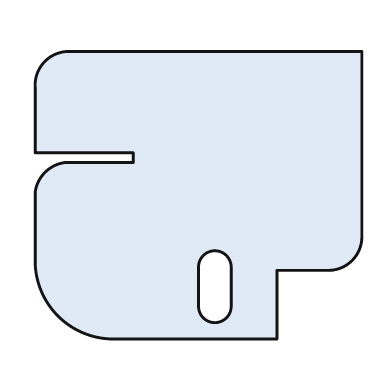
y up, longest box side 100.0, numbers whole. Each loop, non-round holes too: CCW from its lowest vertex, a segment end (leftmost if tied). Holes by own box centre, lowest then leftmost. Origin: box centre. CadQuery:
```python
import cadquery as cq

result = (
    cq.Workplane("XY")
    .moveTo(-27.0, -44.0)
    .lineTo(24.0, -44.0)
    .lineTo(24.0, -23.0)
    .lineTo(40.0, -23.0)
    .threePointArc((47.0, -20.0), (50.0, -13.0))
    .lineTo(50.0, 44.0)
    .lineTo(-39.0, 44.0)
    .threePointArc((-47.0, 41.0), (-50.0, 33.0))
    .lineTo(-50.0, 13.0)
    .lineTo(-20.0, 13.0)
    .lineTo(-20.0, 10.0)
    .lineTo(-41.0, 10.0)
    .threePointArc((-47.0, 7.0), (-50.0, 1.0))
    .lineTo(-50.0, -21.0)
    .threePointArc((-43.0, -37.0), (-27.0, -44.0))
    .close()
    .moveTo(0.0, -34.0)
    .threePointArc((5.0, -39.0), (10.0, -34.0))
    .lineTo(10.0, -22.0)
    .threePointArc((5.0, -17.0), (0.0, -22.0))
    .close()
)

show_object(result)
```